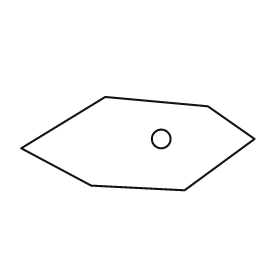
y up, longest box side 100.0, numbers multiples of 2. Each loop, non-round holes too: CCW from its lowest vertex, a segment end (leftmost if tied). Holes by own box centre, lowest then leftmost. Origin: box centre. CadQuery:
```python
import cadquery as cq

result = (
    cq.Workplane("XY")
    .moveTo(20.0, -20.0)
    .lineTo(50.0, 2.0)
    .lineTo(30.0, 16.0)
    .lineTo(-14.0, 20.0)
    .lineTo(-50.0, -2.0)
    .lineTo(-20.0, -18.0)
    .close()
    .moveTo(10.0, 2.0)
    .circle(4.0)
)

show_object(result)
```